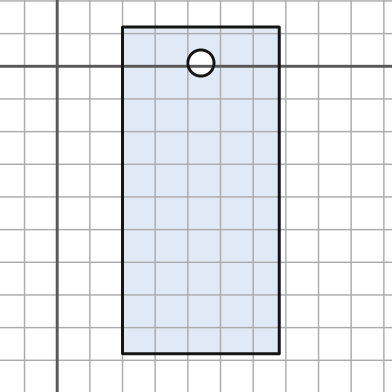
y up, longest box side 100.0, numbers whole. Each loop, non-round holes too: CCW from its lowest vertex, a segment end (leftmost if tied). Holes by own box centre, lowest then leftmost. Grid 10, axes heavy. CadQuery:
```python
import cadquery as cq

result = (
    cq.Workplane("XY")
    .moveTo(20.0, -88.0)
    .lineTo(68.0, -88.0)
    .lineTo(68.0, 12.0)
    .lineTo(20.0, 12.0)
    .close()
    .moveTo(44.0, 1.0)
    .circle(4.0)
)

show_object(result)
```